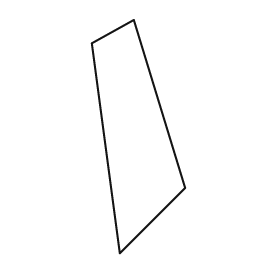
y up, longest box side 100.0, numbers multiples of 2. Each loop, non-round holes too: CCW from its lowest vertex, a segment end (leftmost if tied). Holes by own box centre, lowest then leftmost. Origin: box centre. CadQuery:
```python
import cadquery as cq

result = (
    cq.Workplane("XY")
    .moveTo(-8.0, -50.0)
    .lineTo(20.0, -22.0)
    .lineTo(-2.0, 50.0)
    .lineTo(-20.0, 40.0)
    .close()
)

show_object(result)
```